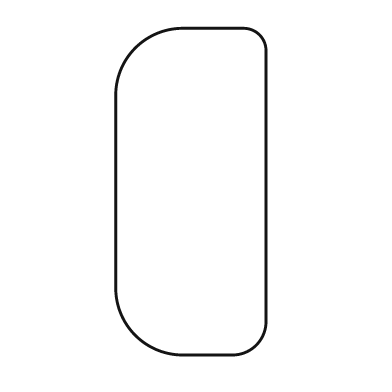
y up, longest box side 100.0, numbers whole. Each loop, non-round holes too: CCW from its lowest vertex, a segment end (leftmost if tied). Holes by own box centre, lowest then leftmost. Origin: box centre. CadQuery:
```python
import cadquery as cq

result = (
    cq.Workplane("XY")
    .moveTo(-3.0, -50.0)
    .lineTo(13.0, -50.0)
    .threePointArc((20.0, -47.0), (23.0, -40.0))
    .lineTo(23.0, 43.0)
    .threePointArc((21.0, 48.0), (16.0, 50.0))
    .lineTo(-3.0, 50.0)
    .threePointArc((-17.0, 44.0), (-23.0, 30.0))
    .lineTo(-23.0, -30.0)
    .threePointArc((-17.0, -44.0), (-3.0, -50.0))
    .close()
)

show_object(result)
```